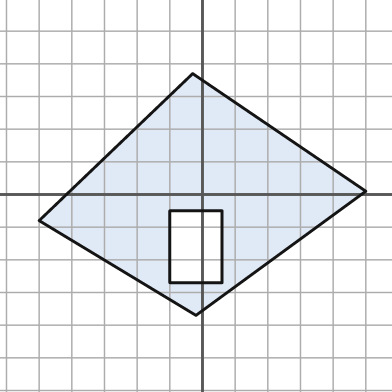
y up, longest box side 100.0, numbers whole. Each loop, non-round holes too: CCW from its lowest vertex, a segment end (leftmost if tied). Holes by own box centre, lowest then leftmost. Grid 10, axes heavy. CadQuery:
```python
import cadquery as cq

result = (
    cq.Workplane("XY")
    .moveTo(-2.0, -37.0)
    .lineTo(50.0, 1.0)
    .lineTo(-3.0, 37.0)
    .lineTo(-50.0, -8.0)
    .close()
    .moveTo(-10.0, -27.0)
    .lineTo(6.0, -27.0)
    .lineTo(6.0, -5.0)
    .lineTo(-10.0, -5.0)
    .close()
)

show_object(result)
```